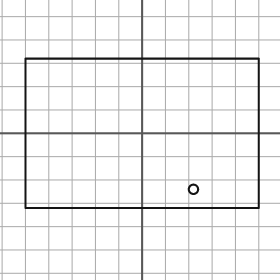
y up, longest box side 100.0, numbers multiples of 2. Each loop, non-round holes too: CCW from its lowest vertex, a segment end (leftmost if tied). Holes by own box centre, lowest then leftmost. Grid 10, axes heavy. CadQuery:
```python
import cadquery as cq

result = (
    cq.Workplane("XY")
    .moveTo(-50.0, -32.0)
    .lineTo(50.0, -32.0)
    .lineTo(50.0, 32.0)
    .lineTo(-50.0, 32.0)
    .close()
    .moveTo(22.0, -24.0)
    .circle(2.0)
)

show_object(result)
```